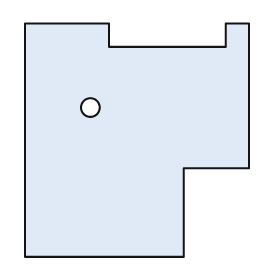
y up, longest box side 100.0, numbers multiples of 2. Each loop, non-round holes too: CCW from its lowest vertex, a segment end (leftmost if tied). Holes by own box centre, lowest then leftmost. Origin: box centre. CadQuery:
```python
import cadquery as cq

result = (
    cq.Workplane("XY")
    .moveTo(-48.0, -50.0)
    .lineTo(20.0, -50.0)
    .lineTo(20.0, -12.0)
    .lineTo(48.0, -12.0)
    .lineTo(48.0, 50.0)
    .lineTo(38.0, 50.0)
    .lineTo(38.0, 40.0)
    .lineTo(-12.0, 40.0)
    .lineTo(-12.0, 50.0)
    .lineTo(-48.0, 50.0)
    .close()
    .moveTo(-20.0, 14.0)
    .circle(4.0)
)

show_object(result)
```